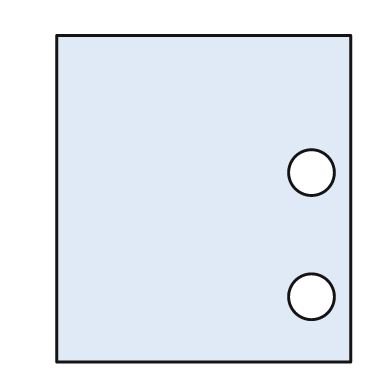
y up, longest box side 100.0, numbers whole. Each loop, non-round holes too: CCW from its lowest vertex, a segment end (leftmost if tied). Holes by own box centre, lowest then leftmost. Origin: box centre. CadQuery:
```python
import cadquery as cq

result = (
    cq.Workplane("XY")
    .moveTo(-45.0, -50.0)
    .lineTo(45.0, -50.0)
    .lineTo(45.0, 50.0)
    .lineTo(-45.0, 50.0)
    .close()
    .moveTo(33.0, -30.0)
    .circle(7.0)
    .moveTo(33.0, 8.0)
    .circle(7.0)
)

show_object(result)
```